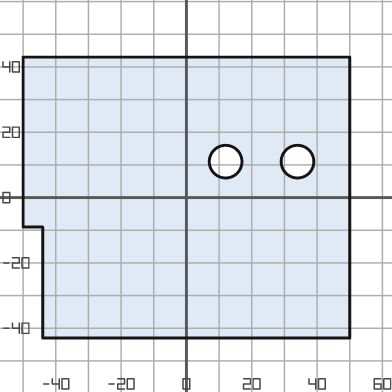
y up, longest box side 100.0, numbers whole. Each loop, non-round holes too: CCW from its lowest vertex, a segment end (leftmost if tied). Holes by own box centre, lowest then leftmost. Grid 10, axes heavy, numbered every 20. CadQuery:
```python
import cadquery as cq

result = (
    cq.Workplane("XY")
    .moveTo(-44.0, -43.0)
    .lineTo(50.0, -43.0)
    .lineTo(50.0, 43.0)
    .lineTo(-50.0, 43.0)
    .lineTo(-50.0, -9.0)
    .lineTo(-44.0, -9.0)
    .close()
    .moveTo(12.0, 11.0)
    .circle(5.0)
    .moveTo(34.0, 11.0)
    .circle(5.0)
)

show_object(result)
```